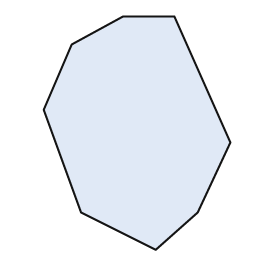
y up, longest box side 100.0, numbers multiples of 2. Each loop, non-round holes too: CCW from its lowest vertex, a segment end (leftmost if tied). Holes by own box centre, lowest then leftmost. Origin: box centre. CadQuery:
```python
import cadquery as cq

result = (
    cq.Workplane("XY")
    .moveTo(8.0, -50.0)
    .lineTo(26.0, -34.0)
    .lineTo(40.0, -4.0)
    .lineTo(16.0, 50.0)
    .lineTo(-6.0, 50.0)
    .lineTo(-28.0, 38.0)
    .lineTo(-40.0, 10.0)
    .lineTo(-24.0, -34.0)
    .close()
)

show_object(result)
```